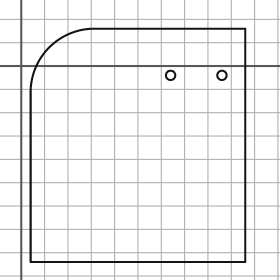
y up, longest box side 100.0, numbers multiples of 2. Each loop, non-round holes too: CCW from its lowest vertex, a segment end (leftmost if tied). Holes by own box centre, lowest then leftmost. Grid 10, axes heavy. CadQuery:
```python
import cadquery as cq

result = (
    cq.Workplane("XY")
    .moveTo(4.0, -84.0)
    .lineTo(96.0, -84.0)
    .lineTo(96.0, 16.0)
    .lineTo(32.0, 16.0)
    .threePointArc((12.0, 8.0), (4.0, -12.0))
    .close()
    .moveTo(64.0, -4.0)
    .circle(2.0)
    .moveTo(86.0, -4.0)
    .circle(2.0)
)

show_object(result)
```